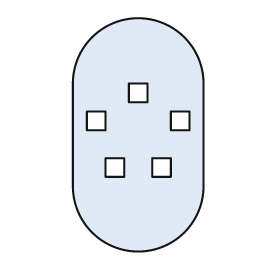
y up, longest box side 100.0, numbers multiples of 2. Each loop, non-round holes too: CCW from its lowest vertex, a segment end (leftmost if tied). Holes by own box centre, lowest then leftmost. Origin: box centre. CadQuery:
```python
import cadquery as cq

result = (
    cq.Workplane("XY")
    .moveTo(-28.0, -22.0)
    .threePointArc((0.0, -50.0), (28.0, -22.0))
    .lineTo(28.0, 22.0)
    .threePointArc((0.0, 50.0), (-28.0, 22.0))
    .close()
    .moveTo(-14.0, -18.0)
    .lineTo(-6.0, -18.0)
    .lineTo(-6.0, -10.0)
    .lineTo(-14.0, -10.0)
    .close()
    .moveTo(6.0, -18.0)
    .lineTo(14.0, -18.0)
    .lineTo(14.0, -10.0)
    .lineTo(6.0, -10.0)
    .close()
    .moveTo(-22.0, 2.0)
    .lineTo(-14.0, 2.0)
    .lineTo(-14.0, 10.0)
    .lineTo(-22.0, 10.0)
    .close()
    .moveTo(14.0, 2.0)
    .lineTo(22.0, 2.0)
    .lineTo(22.0, 10.0)
    .lineTo(14.0, 10.0)
    .close()
    .moveTo(-4.0, 14.0)
    .lineTo(4.0, 14.0)
    .lineTo(4.0, 22.0)
    .lineTo(-4.0, 22.0)
    .close()
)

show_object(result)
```